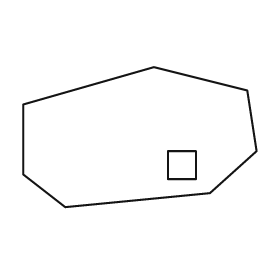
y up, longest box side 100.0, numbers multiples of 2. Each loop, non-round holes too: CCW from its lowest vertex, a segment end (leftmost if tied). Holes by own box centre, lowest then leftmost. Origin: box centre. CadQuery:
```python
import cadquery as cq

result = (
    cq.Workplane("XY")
    .moveTo(-32.0, -30.0)
    .lineTo(30.0, -24.0)
    .lineTo(50.0, -6.0)
    .lineTo(46.0, 20.0)
    .lineTo(6.0, 30.0)
    .lineTo(-50.0, 14.0)
    .lineTo(-50.0, -16.0)
    .close()
    .moveTo(12.0, -18.0)
    .lineTo(24.0, -18.0)
    .lineTo(24.0, -6.0)
    .lineTo(12.0, -6.0)
    .close()
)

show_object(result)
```